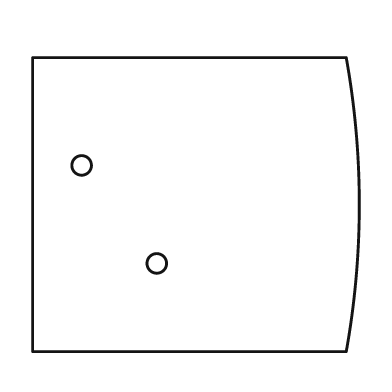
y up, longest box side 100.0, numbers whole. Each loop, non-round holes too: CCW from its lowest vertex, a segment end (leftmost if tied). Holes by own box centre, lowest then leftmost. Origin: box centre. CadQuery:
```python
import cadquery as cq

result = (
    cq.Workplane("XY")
    .moveTo(-50.0, -45.0)
    .lineTo(46.0, -45.0)
    .threePointArc((50.0, 0.0), (46.0, 45.0))
    .lineTo(-50.0, 45.0)
    .close()
    .moveTo(-12.0, -18.0)
    .circle(3.0)
    .moveTo(-35.0, 12.0)
    .circle(3.0)
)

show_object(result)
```